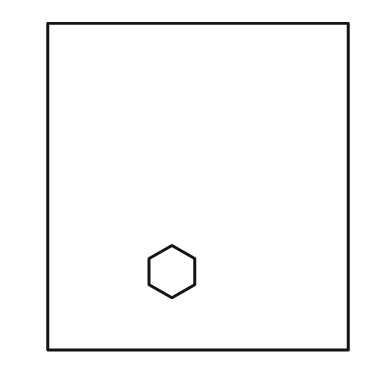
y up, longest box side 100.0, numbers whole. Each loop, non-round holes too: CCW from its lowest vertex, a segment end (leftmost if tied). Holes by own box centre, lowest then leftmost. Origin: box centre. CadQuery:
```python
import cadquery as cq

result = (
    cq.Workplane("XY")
    .moveTo(-46.0, -50.0)
    .lineTo(46.0, -50.0)
    .lineTo(46.0, 50.0)
    .lineTo(-46.0, 50.0)
    .close()
    .moveTo(-8.0, -34.0)
    .lineTo(-1.0, -30.0)
    .lineTo(-1.0, -22.0)
    .lineTo(-8.0, -18.0)
    .lineTo(-15.0, -22.0)
    .lineTo(-15.0, -30.0)
    .close()
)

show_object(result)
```